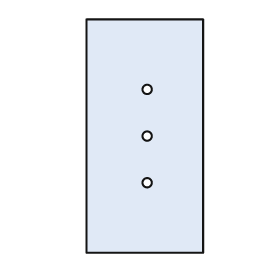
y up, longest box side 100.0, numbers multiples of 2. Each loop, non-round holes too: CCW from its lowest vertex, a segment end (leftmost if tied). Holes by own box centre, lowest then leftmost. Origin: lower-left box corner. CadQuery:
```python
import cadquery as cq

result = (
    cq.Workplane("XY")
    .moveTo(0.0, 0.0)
    .lineTo(50.0, 0.0)
    .lineTo(50.0, 100.0)
    .lineTo(0.0, 100.0)
    .close()
    .moveTo(26.0, 30.0)
    .circle(2.0)
    .moveTo(26.0, 50.0)
    .circle(2.0)
    .moveTo(26.0, 70.0)
    .circle(2.0)
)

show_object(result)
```